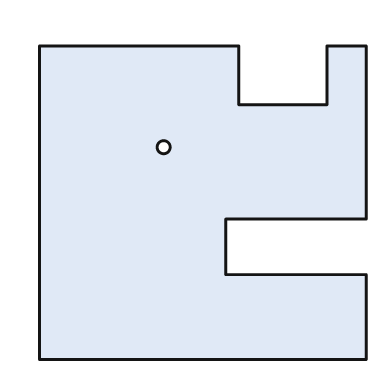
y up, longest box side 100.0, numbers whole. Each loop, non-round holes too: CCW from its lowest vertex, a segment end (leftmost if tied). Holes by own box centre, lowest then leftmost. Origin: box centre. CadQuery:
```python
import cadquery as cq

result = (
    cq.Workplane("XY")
    .moveTo(-50.0, -48.0)
    .lineTo(50.0, -48.0)
    .lineTo(50.0, -22.0)
    .lineTo(7.0, -22.0)
    .lineTo(7.0, -5.0)
    .lineTo(50.0, -5.0)
    .lineTo(50.0, 48.0)
    .lineTo(38.0, 48.0)
    .lineTo(38.0, 30.0)
    .lineTo(11.0, 30.0)
    .lineTo(11.0, 48.0)
    .lineTo(-50.0, 48.0)
    .close()
    .moveTo(-12.0, 17.0)
    .circle(2.0)
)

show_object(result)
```